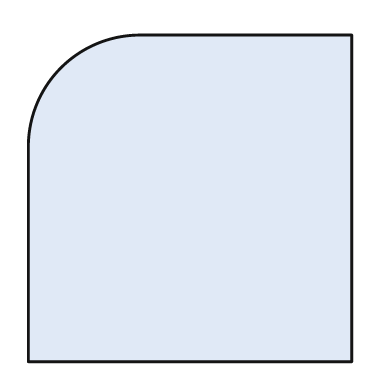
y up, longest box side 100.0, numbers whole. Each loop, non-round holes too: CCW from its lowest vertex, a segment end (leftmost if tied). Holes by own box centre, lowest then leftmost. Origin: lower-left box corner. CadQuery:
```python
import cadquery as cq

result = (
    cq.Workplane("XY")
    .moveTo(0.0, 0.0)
    .lineTo(99.0, 0.0)
    .lineTo(99.0, 100.0)
    .lineTo(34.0, 100.0)
    .threePointArc((10.0, 90.0), (0.0, 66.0))
    .close()
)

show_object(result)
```